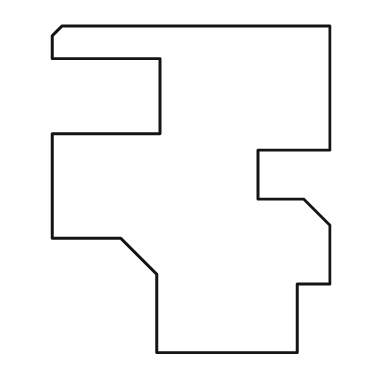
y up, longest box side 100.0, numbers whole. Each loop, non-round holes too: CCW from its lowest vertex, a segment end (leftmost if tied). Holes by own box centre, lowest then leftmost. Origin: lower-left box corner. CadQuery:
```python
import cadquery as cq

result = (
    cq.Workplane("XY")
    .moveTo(32.0, 0.0)
    .lineTo(75.0, 0.0)
    .lineTo(75.0, 21.0)
    .lineTo(85.0, 21.0)
    .lineTo(85.0, 39.0)
    .lineTo(77.0, 47.0)
    .lineTo(63.0, 47.0)
    .lineTo(63.0, 62.0)
    .lineTo(85.0, 62.0)
    .lineTo(85.0, 100.0)
    .lineTo(3.0, 100.0)
    .lineTo(0.0, 97.0)
    .lineTo(0.0, 90.0)
    .lineTo(33.0, 90.0)
    .lineTo(33.0, 67.0)
    .lineTo(0.0, 67.0)
    .lineTo(0.0, 35.0)
    .lineTo(21.0, 35.0)
    .lineTo(32.0, 24.0)
    .close()
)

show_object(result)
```